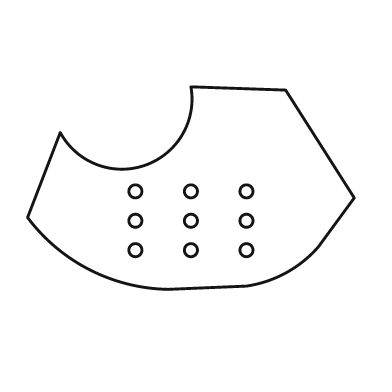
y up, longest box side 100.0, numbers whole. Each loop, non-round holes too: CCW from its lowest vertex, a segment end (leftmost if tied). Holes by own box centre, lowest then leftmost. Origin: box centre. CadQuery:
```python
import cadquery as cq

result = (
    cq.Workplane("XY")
    .moveTo(-7.0, -31.0)
    .lineTo(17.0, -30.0)
    .threePointArc((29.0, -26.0), (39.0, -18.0))
    .lineTo(50.0, -3.0)
    .lineTo(29.0, 30.0)
    .lineTo(0.0, 31.0)
    .threePointArc((-14.0, 7.0), (-40.0, 17.0))
    .lineTo(-50.0, -9.0)
    .threePointArc((-31.0, -25.0), (-7.0, -31.0))
    .close()
    .moveTo(-17.0, -19.0)
    .circle(2.0)
    .moveTo(0.0, -19.0)
    .circle(2.0)
    .moveTo(17.0, -19.0)
    .circle(2.0)
    .moveTo(-17.0, -10.0)
    .circle(2.0)
    .moveTo(0.0, -10.0)
    .circle(2.0)
    .moveTo(17.0, -10.0)
    .circle(2.0)
    .moveTo(-17.0, -1.0)
    .circle(2.0)
    .moveTo(0.0, -1.0)
    .circle(2.0)
    .moveTo(17.0, -1.0)
    .circle(2.0)
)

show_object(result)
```